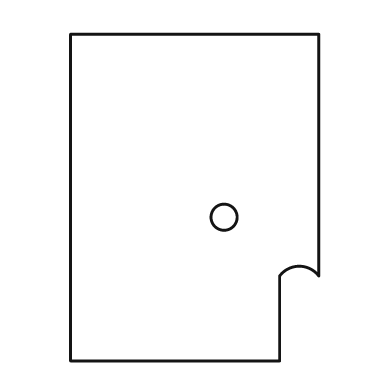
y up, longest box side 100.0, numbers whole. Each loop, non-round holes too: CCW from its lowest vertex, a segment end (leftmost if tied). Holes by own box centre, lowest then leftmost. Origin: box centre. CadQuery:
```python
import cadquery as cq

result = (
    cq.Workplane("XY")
    .moveTo(-38.0, -50.0)
    .lineTo(26.0, -50.0)
    .lineTo(26.0, -24.0)
    .threePointArc((32.0, -21.0), (38.0, -24.0))
    .lineTo(38.0, 50.0)
    .lineTo(-38.0, 50.0)
    .close()
    .moveTo(9.0, -6.0)
    .circle(4.0)
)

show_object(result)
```